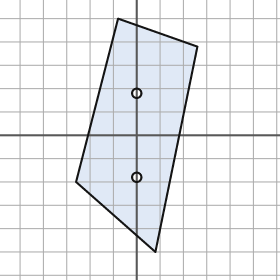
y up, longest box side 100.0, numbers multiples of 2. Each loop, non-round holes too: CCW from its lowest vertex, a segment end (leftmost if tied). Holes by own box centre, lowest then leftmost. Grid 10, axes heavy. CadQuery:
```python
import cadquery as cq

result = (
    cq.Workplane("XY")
    .moveTo(8.0, -50.0)
    .lineTo(26.0, 38.0)
    .lineTo(-8.0, 50.0)
    .lineTo(-26.0, -20.0)
    .close()
    .moveTo(0.0, -18.0)
    .circle(2.0)
    .moveTo(0.0, 18.0)
    .circle(2.0)
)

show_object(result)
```